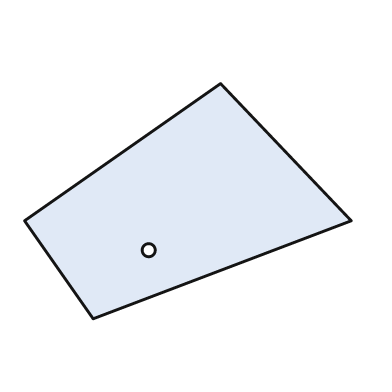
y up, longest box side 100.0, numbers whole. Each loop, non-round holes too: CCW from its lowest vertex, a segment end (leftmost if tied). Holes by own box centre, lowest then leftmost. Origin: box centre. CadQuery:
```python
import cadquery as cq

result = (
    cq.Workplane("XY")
    .moveTo(-29.0, -36.0)
    .lineTo(50.0, -6.0)
    .lineTo(10.0, 36.0)
    .lineTo(-50.0, -6.0)
    .close()
    .moveTo(-12.0, -15.0)
    .circle(2.0)
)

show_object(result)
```